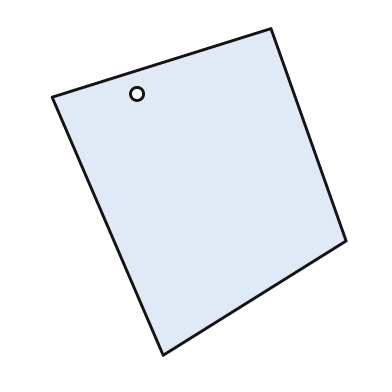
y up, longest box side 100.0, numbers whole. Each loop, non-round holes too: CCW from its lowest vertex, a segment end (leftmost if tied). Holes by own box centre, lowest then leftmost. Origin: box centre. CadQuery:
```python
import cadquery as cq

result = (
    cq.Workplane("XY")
    .moveTo(-11.0, -50.0)
    .lineTo(45.0, -15.0)
    .lineTo(22.0, 50.0)
    .lineTo(-45.0, 29.0)
    .close()
    .moveTo(-19.0, 30.0)
    .circle(2.0)
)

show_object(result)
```